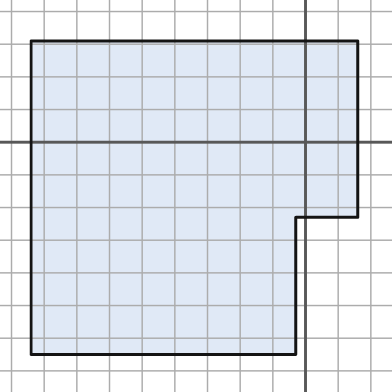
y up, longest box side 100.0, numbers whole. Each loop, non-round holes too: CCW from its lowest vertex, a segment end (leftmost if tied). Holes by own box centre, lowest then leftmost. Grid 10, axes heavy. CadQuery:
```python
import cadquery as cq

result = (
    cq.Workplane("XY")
    .moveTo(-84.0, -65.0)
    .lineTo(-3.0, -65.0)
    .lineTo(-3.0, -23.0)
    .lineTo(16.0, -23.0)
    .lineTo(16.0, 31.0)
    .lineTo(-84.0, 31.0)
    .close()
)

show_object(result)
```